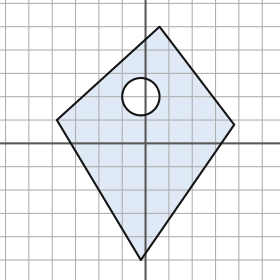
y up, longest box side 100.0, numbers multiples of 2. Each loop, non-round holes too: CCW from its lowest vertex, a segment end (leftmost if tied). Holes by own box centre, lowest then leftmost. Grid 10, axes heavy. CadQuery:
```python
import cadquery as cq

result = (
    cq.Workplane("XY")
    .moveTo(-2.0, -50.0)
    .lineTo(38.0, 8.0)
    .lineTo(6.0, 50.0)
    .lineTo(-38.0, 10.0)
    .close()
    .moveTo(-2.0, 20.0)
    .circle(8.0)
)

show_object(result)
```